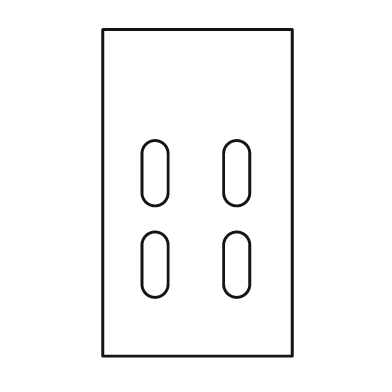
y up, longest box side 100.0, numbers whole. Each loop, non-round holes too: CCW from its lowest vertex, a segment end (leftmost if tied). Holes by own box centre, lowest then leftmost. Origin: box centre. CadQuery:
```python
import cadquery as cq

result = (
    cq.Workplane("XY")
    .moveTo(-29.0, -50.0)
    .lineTo(29.0, -50.0)
    .lineTo(29.0, 50.0)
    .lineTo(-29.0, 50.0)
    .close()
    .moveTo(-17.0, -28.0)
    .threePointArc((-13.0, -32.0), (-9.0, -28.0))
    .lineTo(-9.0, -16.0)
    .threePointArc((-13.0, -12.0), (-17.0, -16.0))
    .close()
    .moveTo(8.0, -28.0)
    .threePointArc((12.0, -32.0), (16.0, -28.0))
    .lineTo(16.0, -16.0)
    .threePointArc((12.0, -12.0), (8.0, -16.0))
    .close()
    .moveTo(-17.0, 0.0)
    .threePointArc((-13.0, -4.0), (-9.0, 0.0))
    .lineTo(-9.0, 12.0)
    .threePointArc((-13.0, 16.0), (-17.0, 12.0))
    .close()
    .moveTo(8.0, 0.0)
    .threePointArc((12.0, -4.0), (16.0, 0.0))
    .lineTo(16.0, 12.0)
    .threePointArc((12.0, 16.0), (8.0, 12.0))
    .close()
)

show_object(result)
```